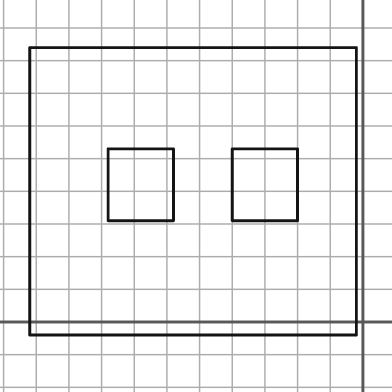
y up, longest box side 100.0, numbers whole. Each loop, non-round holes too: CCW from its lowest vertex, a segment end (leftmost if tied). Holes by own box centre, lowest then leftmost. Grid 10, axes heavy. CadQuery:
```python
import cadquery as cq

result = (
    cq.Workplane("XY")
    .moveTo(-102.0, -4.0)
    .lineTo(-2.0, -4.0)
    .lineTo(-2.0, 84.0)
    .lineTo(-102.0, 84.0)
    .close()
    .moveTo(-78.0, 31.0)
    .lineTo(-58.0, 31.0)
    .lineTo(-58.0, 53.0)
    .lineTo(-78.0, 53.0)
    .close()
    .moveTo(-40.0, 31.0)
    .lineTo(-20.0, 31.0)
    .lineTo(-20.0, 53.0)
    .lineTo(-40.0, 53.0)
    .close()
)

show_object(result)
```